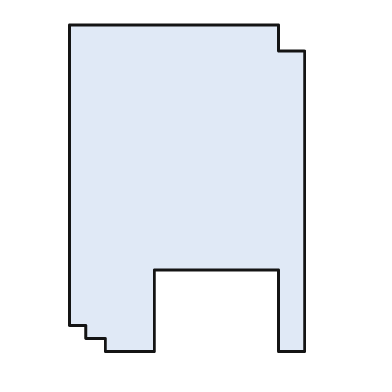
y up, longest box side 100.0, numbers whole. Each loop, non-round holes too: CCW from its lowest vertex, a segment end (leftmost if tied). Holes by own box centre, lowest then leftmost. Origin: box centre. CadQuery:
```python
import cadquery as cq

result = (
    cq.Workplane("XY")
    .moveTo(-25.0, -50.0)
    .lineTo(-10.0, -50.0)
    .lineTo(-10.0, -25.0)
    .lineTo(28.0, -25.0)
    .lineTo(28.0, -50.0)
    .lineTo(36.0, -50.0)
    .lineTo(36.0, 42.0)
    .lineTo(28.0, 42.0)
    .lineTo(28.0, 50.0)
    .lineTo(-36.0, 50.0)
    .lineTo(-36.0, -42.0)
    .lineTo(-31.0, -42.0)
    .lineTo(-31.0, -46.0)
    .lineTo(-25.0, -46.0)
    .close()
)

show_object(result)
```